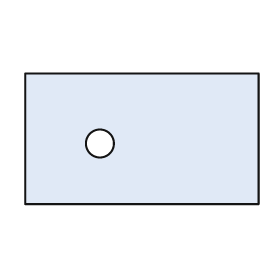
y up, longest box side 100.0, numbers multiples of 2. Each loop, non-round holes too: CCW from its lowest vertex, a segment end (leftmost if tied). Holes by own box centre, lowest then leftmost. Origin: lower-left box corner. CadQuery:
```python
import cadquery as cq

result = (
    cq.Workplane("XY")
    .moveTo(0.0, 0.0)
    .lineTo(100.0, 0.0)
    .lineTo(100.0, 56.0)
    .lineTo(0.0, 56.0)
    .close()
    .moveTo(32.0, 26.0)
    .circle(6.0)
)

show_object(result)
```